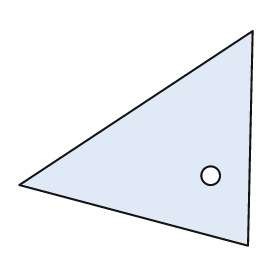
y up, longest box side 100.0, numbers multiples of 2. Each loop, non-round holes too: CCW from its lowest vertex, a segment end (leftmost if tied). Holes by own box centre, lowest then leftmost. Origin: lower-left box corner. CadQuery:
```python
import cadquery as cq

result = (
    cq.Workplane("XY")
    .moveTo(98.0, 0.0)
    .lineTo(100.0, 92.0)
    .lineTo(0.0, 26.0)
    .close()
    .moveTo(82.0, 30.0)
    .circle(4.0)
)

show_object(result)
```